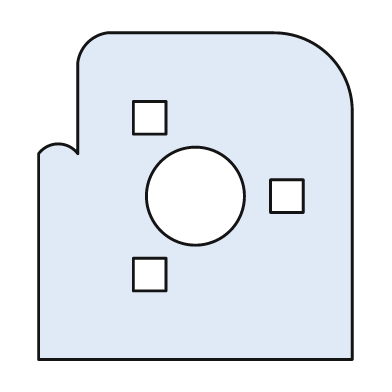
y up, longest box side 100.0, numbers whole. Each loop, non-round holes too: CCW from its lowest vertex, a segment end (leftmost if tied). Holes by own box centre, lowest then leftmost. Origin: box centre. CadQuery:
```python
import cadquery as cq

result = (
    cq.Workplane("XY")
    .moveTo(-48.0, -50.0)
    .lineTo(48.0, -50.0)
    .lineTo(48.0, 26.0)
    .threePointArc((41.0, 43.0), (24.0, 50.0))
    .lineTo(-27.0, 50.0)
    .threePointArc((-33.0, 47.0), (-36.0, 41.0))
    .lineTo(-36.0, 13.0)
    .threePointArc((-42.0, 16.0), (-48.0, 13.0))
    .close()
    .moveTo(-19.0, -29.0)
    .lineTo(-9.0, -29.0)
    .lineTo(-9.0, -19.0)
    .lineTo(-19.0, -19.0)
    .close()
    .moveTo(0.0, 0.0)
    .circle(15.0)
    .moveTo(23.0, -5.0)
    .lineTo(33.0, -5.0)
    .lineTo(33.0, 5.0)
    .lineTo(23.0, 5.0)
    .close()
    .moveTo(-19.0, 19.0)
    .lineTo(-9.0, 19.0)
    .lineTo(-9.0, 29.0)
    .lineTo(-19.0, 29.0)
    .close()
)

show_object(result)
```